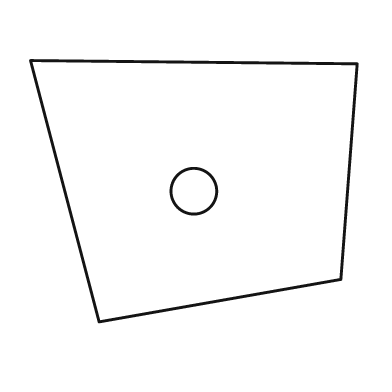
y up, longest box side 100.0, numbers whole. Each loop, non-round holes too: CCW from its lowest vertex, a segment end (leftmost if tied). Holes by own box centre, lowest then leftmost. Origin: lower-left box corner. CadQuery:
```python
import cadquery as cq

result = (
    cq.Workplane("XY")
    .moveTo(21.0, 0.0)
    .lineTo(95.0, 13.0)
    .lineTo(100.0, 79.0)
    .lineTo(0.0, 80.0)
    .close()
    .moveTo(50.0, 40.0)
    .circle(7.0)
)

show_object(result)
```